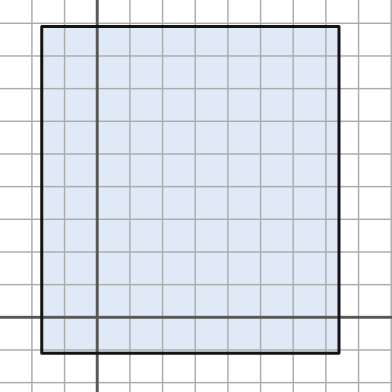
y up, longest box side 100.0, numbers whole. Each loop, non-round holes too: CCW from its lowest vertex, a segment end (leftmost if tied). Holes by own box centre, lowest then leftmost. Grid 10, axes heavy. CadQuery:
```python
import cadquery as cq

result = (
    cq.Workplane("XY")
    .moveTo(-17.0, -11.0)
    .lineTo(74.0, -11.0)
    .lineTo(74.0, 89.0)
    .lineTo(-17.0, 89.0)
    .close()
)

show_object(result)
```